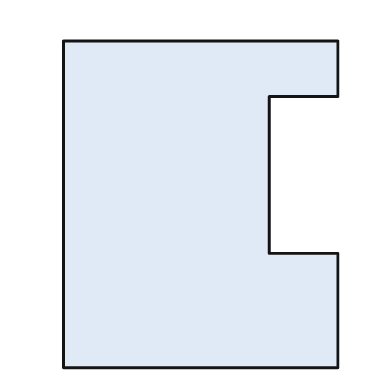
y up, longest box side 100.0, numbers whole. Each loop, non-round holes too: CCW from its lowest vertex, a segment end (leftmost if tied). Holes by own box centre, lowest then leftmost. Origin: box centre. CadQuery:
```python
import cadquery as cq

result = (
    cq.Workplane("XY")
    .moveTo(-42.0, -50.0)
    .lineTo(42.0, -50.0)
    .lineTo(42.0, -15.0)
    .lineTo(21.0, -15.0)
    .lineTo(21.0, 33.0)
    .lineTo(42.0, 33.0)
    .lineTo(42.0, 50.0)
    .lineTo(-42.0, 50.0)
    .close()
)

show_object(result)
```